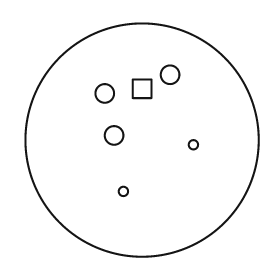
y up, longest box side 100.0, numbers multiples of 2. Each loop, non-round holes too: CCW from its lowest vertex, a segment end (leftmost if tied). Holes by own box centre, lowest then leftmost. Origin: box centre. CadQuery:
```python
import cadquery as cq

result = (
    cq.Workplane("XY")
    .moveTo(0.0, 0.0)
    .circle(50.0)
    .moveTo(-8.0, -22.0)
    .circle(2.0)
    .moveTo(22.0, -2.0)
    .circle(2.0)
    .moveTo(-12.0, 2.0)
    .circle(4.0)
    .moveTo(-16.0, 20.0)
    .circle(4.0)
    .moveTo(-4.0, 18.0)
    .lineTo(4.0, 18.0)
    .lineTo(4.0, 26.0)
    .lineTo(-4.0, 26.0)
    .close()
    .moveTo(12.0, 28.0)
    .circle(4.0)
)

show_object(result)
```